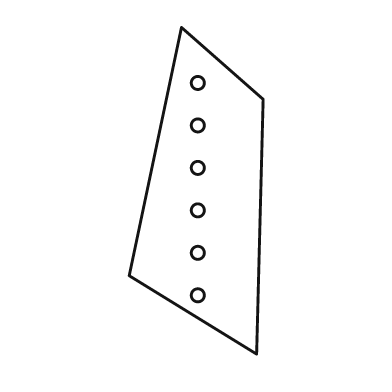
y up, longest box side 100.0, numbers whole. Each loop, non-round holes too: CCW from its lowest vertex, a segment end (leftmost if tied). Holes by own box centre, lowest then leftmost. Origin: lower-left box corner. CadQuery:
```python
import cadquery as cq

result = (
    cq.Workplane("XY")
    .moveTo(39.0, 0.0)
    .lineTo(41.0, 78.0)
    .lineTo(16.0, 100.0)
    .lineTo(0.0, 24.0)
    .close()
    .moveTo(21.0, 18.0)
    .circle(2.0)
    .moveTo(21.0, 31.0)
    .circle(2.0)
    .moveTo(21.0, 44.0)
    .circle(2.0)
    .moveTo(21.0, 57.0)
    .circle(2.0)
    .moveTo(21.0, 70.0)
    .circle(2.0)
    .moveTo(21.0, 83.0)
    .circle(2.0)
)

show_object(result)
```